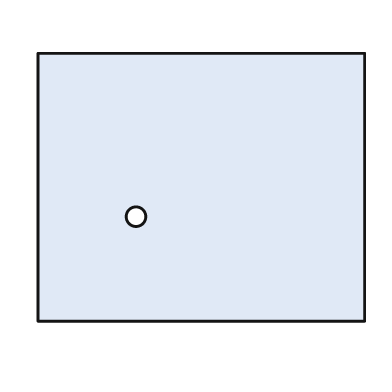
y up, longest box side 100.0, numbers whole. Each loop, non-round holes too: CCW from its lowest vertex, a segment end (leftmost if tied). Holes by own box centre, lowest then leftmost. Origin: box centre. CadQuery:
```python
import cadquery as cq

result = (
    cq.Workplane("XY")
    .moveTo(-50.0, -41.0)
    .lineTo(50.0, -41.0)
    .lineTo(50.0, 41.0)
    .lineTo(-50.0, 41.0)
    .close()
    .moveTo(-20.0, -9.0)
    .circle(3.0)
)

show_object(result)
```